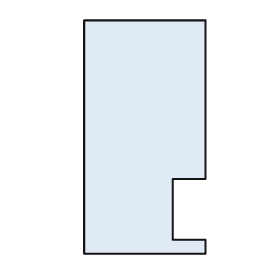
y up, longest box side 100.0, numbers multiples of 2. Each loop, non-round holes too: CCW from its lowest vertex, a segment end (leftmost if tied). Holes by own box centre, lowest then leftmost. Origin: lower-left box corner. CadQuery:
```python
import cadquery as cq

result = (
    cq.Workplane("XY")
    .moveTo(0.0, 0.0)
    .lineTo(52.0, 0.0)
    .lineTo(52.0, 6.0)
    .lineTo(38.0, 6.0)
    .lineTo(38.0, 32.0)
    .lineTo(52.0, 32.0)
    .lineTo(52.0, 100.0)
    .lineTo(0.0, 100.0)
    .close()
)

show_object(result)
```